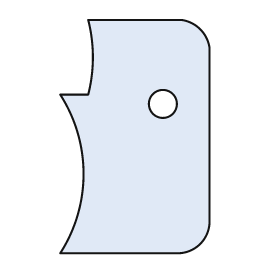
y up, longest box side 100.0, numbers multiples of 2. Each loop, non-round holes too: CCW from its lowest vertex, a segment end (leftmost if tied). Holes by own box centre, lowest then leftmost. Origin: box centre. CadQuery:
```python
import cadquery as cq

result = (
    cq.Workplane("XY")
    .moveTo(-32.0, -50.0)
    .lineTo(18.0, -50.0)
    .threePointArc((28.0, -46.0), (32.0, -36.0))
    .lineTo(32.0, 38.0)
    .threePointArc((28.0, 46.0), (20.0, 50.0))
    .lineTo(-20.0, 50.0)
    .threePointArc((-18.0, 34.0), (-20.0, 18.0))
    .lineTo(-32.0, 18.0)
    .threePointArc((-22.0, -16.0), (-32.0, -50.0))
    .close()
    .moveTo(12.0, 14.0)
    .circle(6.0)
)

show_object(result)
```